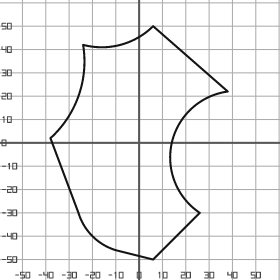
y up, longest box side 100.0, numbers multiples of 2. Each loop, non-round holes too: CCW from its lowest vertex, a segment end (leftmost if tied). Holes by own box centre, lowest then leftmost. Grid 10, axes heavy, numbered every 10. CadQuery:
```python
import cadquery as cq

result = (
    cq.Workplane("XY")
    .moveTo(6.0, -50.0)
    .lineTo(26.0, -30.0)
    .threePointArc((14.0, 0.0), (38.0, 22.0))
    .lineTo(6.0, 50.0)
    .threePointArc((-8.0, 42.0), (-24.0, 42.0))
    .threePointArc((-26.0, 20.0), (-38.0, 2.0))
    .lineTo(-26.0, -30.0)
    .threePointArc((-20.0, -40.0), (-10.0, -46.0))
    .close()
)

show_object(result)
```